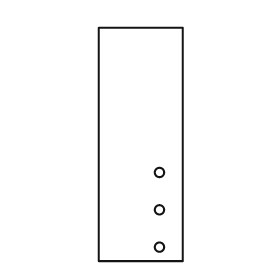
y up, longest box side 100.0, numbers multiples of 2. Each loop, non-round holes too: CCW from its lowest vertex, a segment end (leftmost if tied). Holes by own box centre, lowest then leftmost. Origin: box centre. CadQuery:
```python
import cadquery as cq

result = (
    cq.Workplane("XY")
    .moveTo(-18.0, -50.0)
    .lineTo(18.0, -50.0)
    .lineTo(18.0, 50.0)
    .lineTo(-18.0, 50.0)
    .close()
    .moveTo(8.0, -44.0)
    .circle(2.0)
    .moveTo(8.0, -28.0)
    .circle(2.0)
    .moveTo(8.0, -12.0)
    .circle(2.0)
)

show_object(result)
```